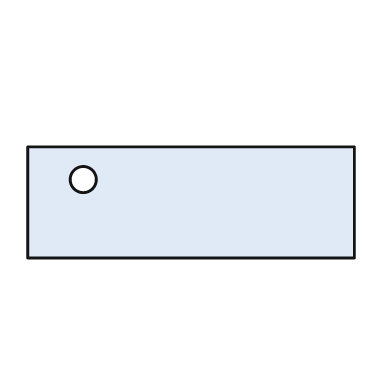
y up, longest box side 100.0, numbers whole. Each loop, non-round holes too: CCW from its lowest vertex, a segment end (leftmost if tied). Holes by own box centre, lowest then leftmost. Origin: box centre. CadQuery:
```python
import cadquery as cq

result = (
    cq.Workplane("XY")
    .moveTo(-50.0, -17.0)
    .lineTo(50.0, -17.0)
    .lineTo(50.0, 17.0)
    .lineTo(-50.0, 17.0)
    .close()
    .moveTo(-33.0, 7.0)
    .circle(4.0)
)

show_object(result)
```